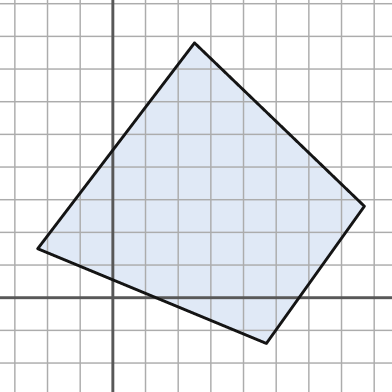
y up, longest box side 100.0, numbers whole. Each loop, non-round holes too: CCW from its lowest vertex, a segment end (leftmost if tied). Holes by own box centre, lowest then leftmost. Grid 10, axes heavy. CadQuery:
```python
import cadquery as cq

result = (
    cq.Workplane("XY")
    .moveTo(47.0, -14.0)
    .lineTo(77.0, 28.0)
    .lineTo(25.0, 78.0)
    .lineTo(-23.0, 15.0)
    .close()
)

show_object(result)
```